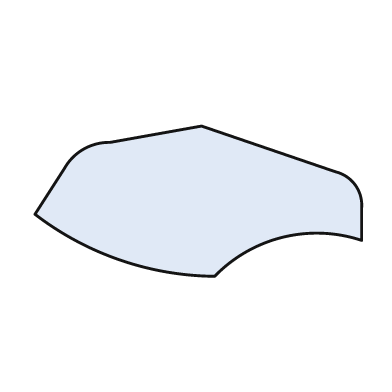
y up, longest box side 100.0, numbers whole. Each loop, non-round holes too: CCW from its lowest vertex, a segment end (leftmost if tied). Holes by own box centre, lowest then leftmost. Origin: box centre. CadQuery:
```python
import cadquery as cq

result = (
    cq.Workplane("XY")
    .moveTo(5.0, -23.0)
    .threePointArc((26.0, -11.0), (50.0, -12.0))
    .lineTo(50.0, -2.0)
    .threePointArc((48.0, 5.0), (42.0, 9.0))
    .lineTo(1.0, 23.0)
    .lineTo(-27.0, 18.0)
    .threePointArc((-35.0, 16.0), (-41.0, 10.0))
    .lineTo(-50.0, -4.0)
    .threePointArc((-24.0, -18.0), (5.0, -23.0))
    .close()
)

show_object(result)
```